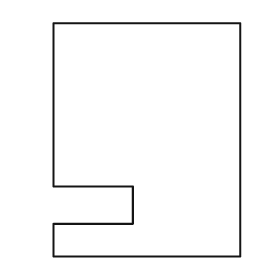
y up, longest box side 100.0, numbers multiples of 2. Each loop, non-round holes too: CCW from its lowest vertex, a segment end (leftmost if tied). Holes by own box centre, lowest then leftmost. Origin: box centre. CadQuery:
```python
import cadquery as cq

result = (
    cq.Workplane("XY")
    .moveTo(-40.0, -50.0)
    .lineTo(40.0, -50.0)
    .lineTo(40.0, 50.0)
    .lineTo(-40.0, 50.0)
    .lineTo(-40.0, -20.0)
    .lineTo(-6.0, -20.0)
    .lineTo(-6.0, -36.0)
    .lineTo(-40.0, -36.0)
    .close()
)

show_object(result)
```